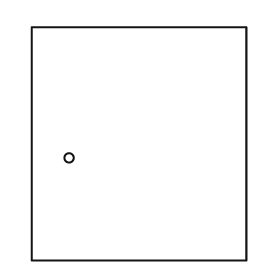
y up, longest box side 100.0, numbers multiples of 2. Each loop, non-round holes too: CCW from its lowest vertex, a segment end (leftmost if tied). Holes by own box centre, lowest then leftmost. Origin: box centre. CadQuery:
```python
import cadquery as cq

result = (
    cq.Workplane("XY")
    .moveTo(-46.0, -50.0)
    .lineTo(46.0, -50.0)
    .lineTo(46.0, 50.0)
    .lineTo(-46.0, 50.0)
    .close()
    .moveTo(-30.0, -6.0)
    .circle(2.0)
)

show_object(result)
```